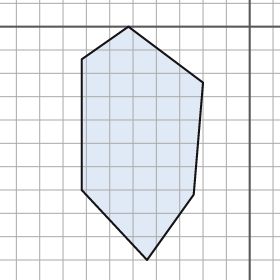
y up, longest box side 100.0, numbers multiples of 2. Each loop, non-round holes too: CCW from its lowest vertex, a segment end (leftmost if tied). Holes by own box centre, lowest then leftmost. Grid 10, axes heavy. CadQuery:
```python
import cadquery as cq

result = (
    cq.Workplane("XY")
    .moveTo(-44.0, -100.0)
    .lineTo(-24.0, -72.0)
    .lineTo(-20.0, -24.0)
    .lineTo(-52.0, 0.0)
    .lineTo(-72.0, -14.0)
    .lineTo(-72.0, -70.0)
    .close()
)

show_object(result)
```